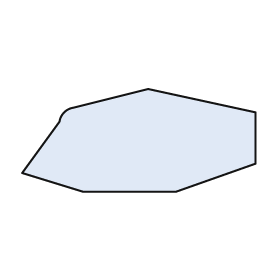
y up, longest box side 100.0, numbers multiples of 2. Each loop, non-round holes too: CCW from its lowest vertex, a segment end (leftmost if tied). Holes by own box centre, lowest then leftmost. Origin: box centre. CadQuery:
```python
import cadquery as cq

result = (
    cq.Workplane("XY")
    .moveTo(-24.0, -22.0)
    .lineTo(16.0, -22.0)
    .lineTo(50.0, -10.0)
    .lineTo(50.0, 12.0)
    .lineTo(4.0, 22.0)
    .lineTo(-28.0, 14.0)
    .threePointArc((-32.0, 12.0), (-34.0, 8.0))
    .lineTo(-50.0, -14.0)
    .close()
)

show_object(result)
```